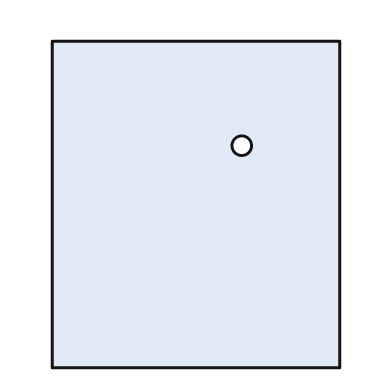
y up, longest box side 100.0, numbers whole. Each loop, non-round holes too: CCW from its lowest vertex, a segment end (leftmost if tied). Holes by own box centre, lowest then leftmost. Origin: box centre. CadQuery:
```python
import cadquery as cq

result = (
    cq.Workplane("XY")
    .moveTo(-44.0, -50.0)
    .lineTo(44.0, -50.0)
    .lineTo(44.0, 50.0)
    .lineTo(-44.0, 50.0)
    .close()
    .moveTo(14.0, 18.0)
    .circle(3.0)
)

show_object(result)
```